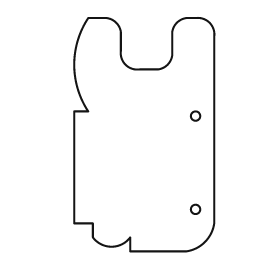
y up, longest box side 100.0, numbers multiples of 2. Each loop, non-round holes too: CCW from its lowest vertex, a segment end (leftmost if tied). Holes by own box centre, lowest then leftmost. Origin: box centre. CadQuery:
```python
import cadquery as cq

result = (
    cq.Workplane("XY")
    .moveTo(-6.0, -50.0)
    .lineTo(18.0, -50.0)
    .threePointArc((26.0, -46.0), (30.0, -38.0))
    .lineTo(30.0, 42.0)
    .threePointArc((28.0, 48.0), (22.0, 50.0))
    .lineTo(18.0, 50.0)
    .threePointArc((14.0, 48.0), (12.0, 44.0))
    .lineTo(12.0, 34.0)
    .threePointArc((10.0, 30.0), (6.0, 28.0))
    .lineTo(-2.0, 28.0)
    .threePointArc((-8.0, 30.0), (-10.0, 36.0))
    .lineTo(-10.0, 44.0)
    .threePointArc((-12.0, 48.0), (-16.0, 50.0))
    .lineTo(-24.0, 50.0)
    .threePointArc((-30.0, 30.0), (-24.0, 10.0))
    .lineTo(-30.0, 10.0)
    .lineTo(-30.0, -38.0)
    .lineTo(-22.0, -38.0)
    .lineTo(-22.0, -44.0)
    .threePointArc((-14.0, -48.0), (-6.0, -44.0))
    .close()
    .moveTo(22.0, -32.0)
    .circle(2.0)
    .moveTo(22.0, 8.0)
    .circle(2.0)
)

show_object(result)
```